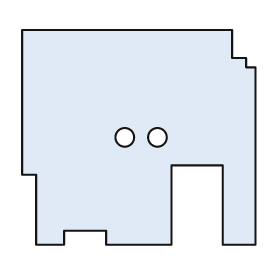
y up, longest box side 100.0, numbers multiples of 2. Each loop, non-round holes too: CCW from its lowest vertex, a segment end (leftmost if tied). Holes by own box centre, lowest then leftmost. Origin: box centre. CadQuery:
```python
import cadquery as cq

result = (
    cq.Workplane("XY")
    .moveTo(-44.0, -46.0)
    .lineTo(-32.0, -46.0)
    .lineTo(-32.0, -40.0)
    .lineTo(-14.0, -40.0)
    .lineTo(-14.0, -46.0)
    .lineTo(14.0, -46.0)
    .lineTo(14.0, -12.0)
    .lineTo(36.0, -12.0)
    .lineTo(36.0, -46.0)
    .lineTo(50.0, -46.0)
    .lineTo(50.0, 30.0)
    .lineTo(46.0, 30.0)
    .lineTo(46.0, 34.0)
    .lineTo(40.0, 34.0)
    .lineTo(40.0, 46.0)
    .lineTo(-50.0, 46.0)
    .lineTo(-50.0, -16.0)
    .lineTo(-44.0, -16.0)
    .close()
    .moveTo(-6.0, 0.0)
    .circle(4.0)
    .moveTo(8.0, 0.0)
    .circle(4.0)
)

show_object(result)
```